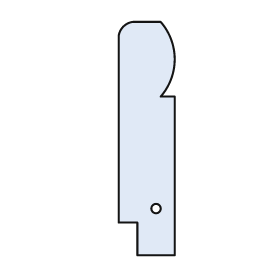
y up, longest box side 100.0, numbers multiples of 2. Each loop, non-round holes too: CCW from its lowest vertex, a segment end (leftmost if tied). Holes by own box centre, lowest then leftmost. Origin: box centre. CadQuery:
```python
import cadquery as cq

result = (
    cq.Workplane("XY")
    .moveTo(-4.0, -50.0)
    .lineTo(12.0, -50.0)
    .lineTo(12.0, 18.0)
    .lineTo(6.0, 18.0)
    .threePointArc((12.0, 34.0), (6.0, 50.0))
    .lineTo(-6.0, 50.0)
    .threePointArc((-10.0, 48.0), (-12.0, 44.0))
    .lineTo(-12.0, -36.0)
    .lineTo(-4.0, -36.0)
    .close()
    .moveTo(4.0, -30.0)
    .circle(2.0)
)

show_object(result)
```